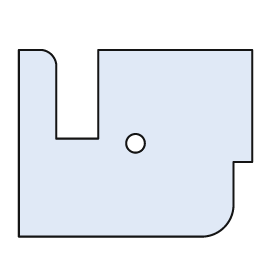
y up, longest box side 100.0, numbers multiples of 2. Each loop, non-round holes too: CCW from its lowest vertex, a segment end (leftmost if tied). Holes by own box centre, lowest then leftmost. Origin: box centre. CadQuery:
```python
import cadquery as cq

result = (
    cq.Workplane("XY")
    .moveTo(-50.0, -40.0)
    .lineTo(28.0, -40.0)
    .threePointArc((38.0, -36.0), (42.0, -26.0))
    .lineTo(42.0, -8.0)
    .lineTo(50.0, -8.0)
    .lineTo(50.0, 40.0)
    .lineTo(-16.0, 40.0)
    .lineTo(-16.0, 2.0)
    .lineTo(-34.0, 2.0)
    .lineTo(-34.0, 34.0)
    .threePointArc((-36.0, 38.0), (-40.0, 40.0))
    .lineTo(-50.0, 40.0)
    .close()
    .moveTo(0.0, 0.0)
    .circle(4.0)
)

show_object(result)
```